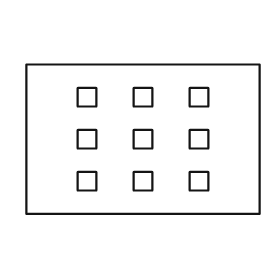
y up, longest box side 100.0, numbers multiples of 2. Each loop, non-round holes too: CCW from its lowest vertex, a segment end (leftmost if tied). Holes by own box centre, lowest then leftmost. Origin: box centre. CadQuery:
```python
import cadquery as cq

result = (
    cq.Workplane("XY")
    .moveTo(-50.0, -32.0)
    .lineTo(50.0, -32.0)
    .lineTo(50.0, 32.0)
    .lineTo(-50.0, 32.0)
    .close()
    .moveTo(-28.0, -22.0)
    .lineTo(-20.0, -22.0)
    .lineTo(-20.0, -14.0)
    .lineTo(-28.0, -14.0)
    .close()
    .moveTo(-4.0, -22.0)
    .lineTo(4.0, -22.0)
    .lineTo(4.0, -14.0)
    .lineTo(-4.0, -14.0)
    .close()
    .moveTo(20.0, -22.0)
    .lineTo(28.0, -22.0)
    .lineTo(28.0, -14.0)
    .lineTo(20.0, -14.0)
    .close()
    .moveTo(-28.0, -4.0)
    .lineTo(-20.0, -4.0)
    .lineTo(-20.0, 4.0)
    .lineTo(-28.0, 4.0)
    .close()
    .moveTo(-4.0, -4.0)
    .lineTo(4.0, -4.0)
    .lineTo(4.0, 4.0)
    .lineTo(-4.0, 4.0)
    .close()
    .moveTo(20.0, -4.0)
    .lineTo(28.0, -4.0)
    .lineTo(28.0, 4.0)
    .lineTo(20.0, 4.0)
    .close()
    .moveTo(-28.0, 14.0)
    .lineTo(-20.0, 14.0)
    .lineTo(-20.0, 22.0)
    .lineTo(-28.0, 22.0)
    .close()
    .moveTo(-4.0, 14.0)
    .lineTo(4.0, 14.0)
    .lineTo(4.0, 22.0)
    .lineTo(-4.0, 22.0)
    .close()
    .moveTo(20.0, 14.0)
    .lineTo(28.0, 14.0)
    .lineTo(28.0, 22.0)
    .lineTo(20.0, 22.0)
    .close()
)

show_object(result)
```